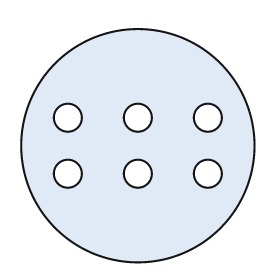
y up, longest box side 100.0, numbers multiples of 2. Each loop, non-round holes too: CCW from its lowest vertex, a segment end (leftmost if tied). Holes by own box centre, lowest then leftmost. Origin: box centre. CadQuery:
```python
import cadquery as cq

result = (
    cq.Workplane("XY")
    .moveTo(0.0, 0.0)
    .circle(50.0)
    .moveTo(-30.0, -12.0)
    .circle(6.0)
    .moveTo(0.0, -12.0)
    .circle(6.0)
    .moveTo(30.0, -12.0)
    .circle(6.0)
    .moveTo(-30.0, 12.0)
    .circle(6.0)
    .moveTo(0.0, 12.0)
    .circle(6.0)
    .moveTo(30.0, 12.0)
    .circle(6.0)
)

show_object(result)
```